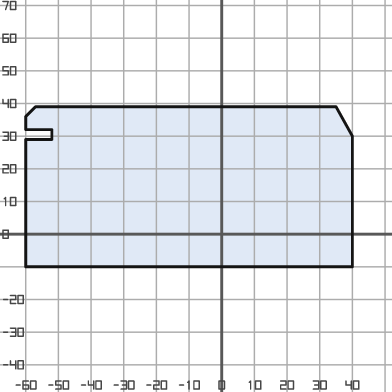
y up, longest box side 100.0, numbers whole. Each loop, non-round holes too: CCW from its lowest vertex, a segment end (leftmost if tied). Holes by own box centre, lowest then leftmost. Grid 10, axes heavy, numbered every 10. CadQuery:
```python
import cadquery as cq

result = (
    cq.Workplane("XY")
    .moveTo(-60.0, -10.0)
    .lineTo(40.0, -10.0)
    .lineTo(40.0, 30.0)
    .lineTo(35.0, 39.0)
    .lineTo(-57.0, 39.0)
    .lineTo(-60.0, 36.0)
    .lineTo(-60.0, 32.0)
    .lineTo(-52.0, 32.0)
    .lineTo(-52.0, 29.0)
    .lineTo(-60.0, 29.0)
    .close()
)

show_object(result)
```